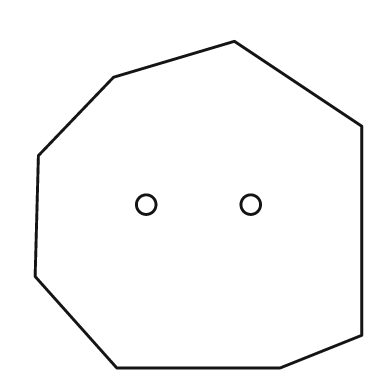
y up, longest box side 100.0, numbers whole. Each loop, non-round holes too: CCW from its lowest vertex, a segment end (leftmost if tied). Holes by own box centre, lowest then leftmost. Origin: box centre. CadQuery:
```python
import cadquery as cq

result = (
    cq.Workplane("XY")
    .moveTo(-25.0, -50.0)
    .lineTo(25.0, -50.0)
    .lineTo(50.0, -40.0)
    .lineTo(50.0, 24.0)
    .lineTo(11.0, 50.0)
    .lineTo(-26.0, 39.0)
    .lineTo(-49.0, 15.0)
    .lineTo(-50.0, -22.0)
    .close()
    .moveTo(-16.0, 0.0)
    .circle(3.0)
    .moveTo(16.0, 0.0)
    .circle(3.0)
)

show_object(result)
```